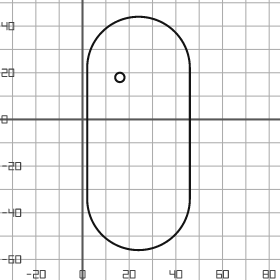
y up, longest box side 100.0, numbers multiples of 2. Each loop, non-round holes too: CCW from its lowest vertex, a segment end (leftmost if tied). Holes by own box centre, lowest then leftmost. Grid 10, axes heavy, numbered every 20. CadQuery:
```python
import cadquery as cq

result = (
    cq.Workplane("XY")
    .moveTo(2.0, -34.0)
    .threePointArc((24.0, -56.0), (46.0, -34.0))
    .lineTo(46.0, 22.0)
    .threePointArc((24.0, 44.0), (2.0, 22.0))
    .close()
    .moveTo(16.0, 18.0)
    .circle(2.0)
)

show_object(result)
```